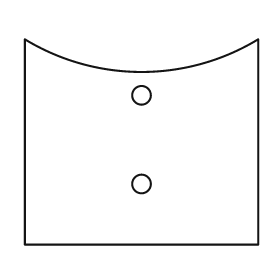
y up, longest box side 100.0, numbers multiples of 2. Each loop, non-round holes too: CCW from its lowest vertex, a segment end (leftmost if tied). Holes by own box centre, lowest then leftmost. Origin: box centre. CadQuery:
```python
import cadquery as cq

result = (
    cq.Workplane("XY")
    .moveTo(-50.0, -44.0)
    .lineTo(50.0, -44.0)
    .lineTo(50.0, 44.0)
    .threePointArc((0.0, 30.0), (-50.0, 44.0))
    .close()
    .moveTo(0.0, -18.0)
    .circle(4.0)
    .moveTo(0.0, 20.0)
    .circle(4.0)
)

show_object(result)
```